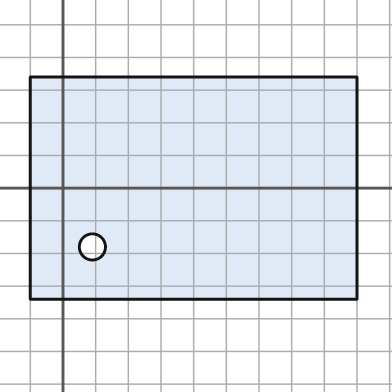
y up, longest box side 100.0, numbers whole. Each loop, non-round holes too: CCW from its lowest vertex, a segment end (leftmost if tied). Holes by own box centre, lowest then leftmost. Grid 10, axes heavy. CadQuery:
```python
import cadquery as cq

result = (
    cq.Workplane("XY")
    .moveTo(-10.0, -34.0)
    .lineTo(90.0, -34.0)
    .lineTo(90.0, 34.0)
    .lineTo(-10.0, 34.0)
    .close()
    .moveTo(9.0, -18.0)
    .circle(4.0)
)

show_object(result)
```